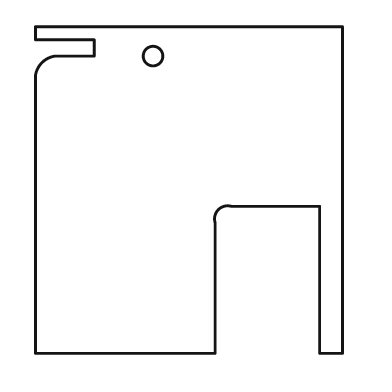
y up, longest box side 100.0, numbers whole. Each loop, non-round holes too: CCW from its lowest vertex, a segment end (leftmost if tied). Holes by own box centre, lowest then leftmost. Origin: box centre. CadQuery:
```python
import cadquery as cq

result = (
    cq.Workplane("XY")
    .moveTo(-47.0, -50.0)
    .lineTo(8.0, -50.0)
    .lineTo(8.0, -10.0)
    .threePointArc((9.0, -6.0), (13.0, -5.0))
    .lineTo(40.0, -5.0)
    .lineTo(40.0, -50.0)
    .lineTo(47.0, -50.0)
    .lineTo(47.0, 50.0)
    .lineTo(-47.0, 50.0)
    .lineTo(-47.0, 46.0)
    .lineTo(-29.0, 46.0)
    .lineTo(-29.0, 41.0)
    .lineTo(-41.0, 41.0)
    .threePointArc((-45.0, 39.0), (-47.0, 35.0))
    .close()
    .moveTo(-11.0, 41.0)
    .circle(3.0)
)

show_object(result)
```